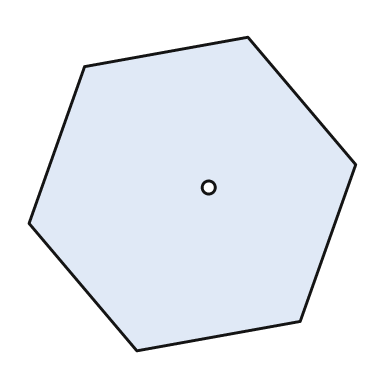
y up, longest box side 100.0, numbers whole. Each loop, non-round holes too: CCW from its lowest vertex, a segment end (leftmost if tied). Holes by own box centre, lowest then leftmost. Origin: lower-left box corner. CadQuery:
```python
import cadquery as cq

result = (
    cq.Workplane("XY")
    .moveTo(33.0, 0.0)
    .lineTo(83.0, 9.0)
    .lineTo(100.0, 57.0)
    .lineTo(67.0, 96.0)
    .lineTo(17.0, 87.0)
    .lineTo(0.0, 39.0)
    .close()
    .moveTo(55.0, 50.0)
    .circle(2.0)
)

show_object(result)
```